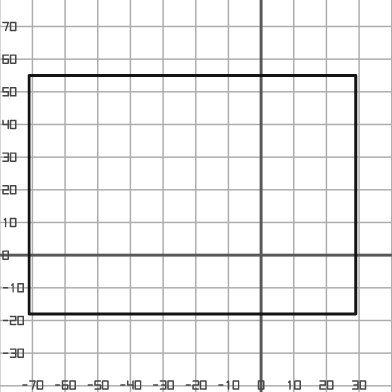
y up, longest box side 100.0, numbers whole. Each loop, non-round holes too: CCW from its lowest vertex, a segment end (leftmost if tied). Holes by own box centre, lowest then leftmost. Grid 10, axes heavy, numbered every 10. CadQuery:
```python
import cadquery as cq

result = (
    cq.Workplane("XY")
    .moveTo(-71.0, -18.0)
    .lineTo(29.0, -18.0)
    .lineTo(29.0, 55.0)
    .lineTo(-71.0, 55.0)
    .close()
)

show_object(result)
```